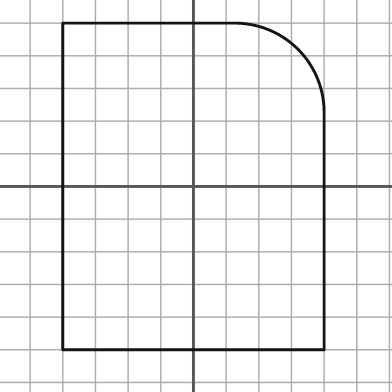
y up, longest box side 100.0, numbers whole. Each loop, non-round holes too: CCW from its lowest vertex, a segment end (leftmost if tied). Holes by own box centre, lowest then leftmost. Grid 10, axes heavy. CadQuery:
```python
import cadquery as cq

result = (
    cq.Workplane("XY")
    .moveTo(-40.0, -50.0)
    .lineTo(40.0, -50.0)
    .lineTo(40.0, 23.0)
    .threePointArc((32.0, 42.0), (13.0, 50.0))
    .lineTo(-40.0, 50.0)
    .close()
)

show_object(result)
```